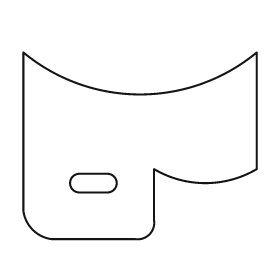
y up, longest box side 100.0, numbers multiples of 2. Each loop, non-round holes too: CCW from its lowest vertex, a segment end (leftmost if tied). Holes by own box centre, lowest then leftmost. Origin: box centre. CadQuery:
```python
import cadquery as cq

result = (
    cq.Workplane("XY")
    .moveTo(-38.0, -40.0)
    .lineTo(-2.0, -40.0)
    .threePointArc((4.0, -38.0), (6.0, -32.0))
    .lineTo(6.0, -10.0)
    .threePointArc((28.0, -16.0), (50.0, -10.0))
    .lineTo(50.0, 40.0)
    .threePointArc((0.0, 22.0), (-50.0, 40.0))
    .lineTo(-50.0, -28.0)
    .threePointArc((-46.0, -36.0), (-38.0, -40.0))
    .close()
    .moveTo(-26.0, -20.0)
    .lineTo(-14.0, -20.0)
    .threePointArc((-10.0, -16.0), (-14.0, -12.0))
    .lineTo(-26.0, -12.0)
    .threePointArc((-30.0, -16.0), (-26.0, -20.0))
    .close()
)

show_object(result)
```